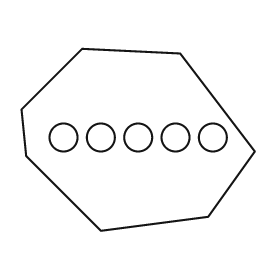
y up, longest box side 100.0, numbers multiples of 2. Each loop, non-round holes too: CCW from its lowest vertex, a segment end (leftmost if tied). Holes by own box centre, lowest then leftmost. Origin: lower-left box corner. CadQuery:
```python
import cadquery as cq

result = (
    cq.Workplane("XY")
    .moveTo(34.0, 0.0)
    .lineTo(80.0, 6.0)
    .lineTo(100.0, 34.0)
    .lineTo(68.0, 76.0)
    .lineTo(26.0, 78.0)
    .lineTo(0.0, 52.0)
    .lineTo(2.0, 32.0)
    .close()
    .moveTo(18.0, 40.0)
    .circle(6.0)
    .moveTo(34.0, 40.0)
    .circle(6.0)
    .moveTo(50.0, 40.0)
    .circle(6.0)
    .moveTo(66.0, 40.0)
    .circle(6.0)
    .moveTo(82.0, 40.0)
    .circle(6.0)
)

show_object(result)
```